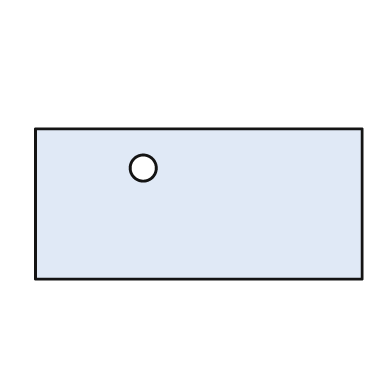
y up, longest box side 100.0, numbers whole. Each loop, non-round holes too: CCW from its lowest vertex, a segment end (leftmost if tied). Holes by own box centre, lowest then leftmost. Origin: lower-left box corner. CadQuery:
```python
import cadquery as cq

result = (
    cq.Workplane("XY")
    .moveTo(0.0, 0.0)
    .lineTo(100.0, 0.0)
    .lineTo(100.0, 46.0)
    .lineTo(0.0, 46.0)
    .close()
    .moveTo(33.0, 34.0)
    .circle(4.0)
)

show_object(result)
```